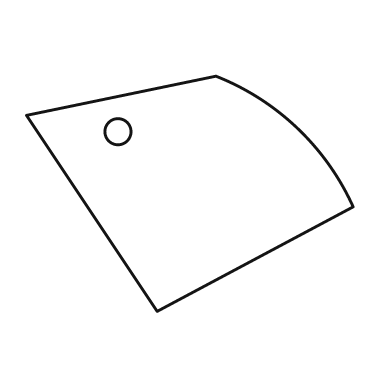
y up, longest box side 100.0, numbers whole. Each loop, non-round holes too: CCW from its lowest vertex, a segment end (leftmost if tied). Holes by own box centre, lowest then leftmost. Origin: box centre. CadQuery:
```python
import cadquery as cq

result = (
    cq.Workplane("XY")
    .moveTo(-10.0, -36.0)
    .lineTo(50.0, -4.0)
    .threePointArc((33.0, 20.0), (8.0, 36.0))
    .lineTo(-50.0, 24.0)
    .close()
    .moveTo(-22.0, 19.0)
    .circle(4.0)
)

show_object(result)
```